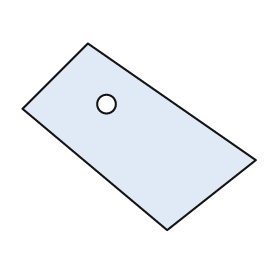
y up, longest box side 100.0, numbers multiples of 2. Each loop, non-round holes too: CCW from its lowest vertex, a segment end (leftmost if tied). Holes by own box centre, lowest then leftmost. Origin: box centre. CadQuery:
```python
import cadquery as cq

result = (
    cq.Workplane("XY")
    .moveTo(12.0, -40.0)
    .lineTo(50.0, -10.0)
    .lineTo(-22.0, 40.0)
    .lineTo(-50.0, 12.0)
    .close()
    .moveTo(-14.0, 14.0)
    .circle(4.0)
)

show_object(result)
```